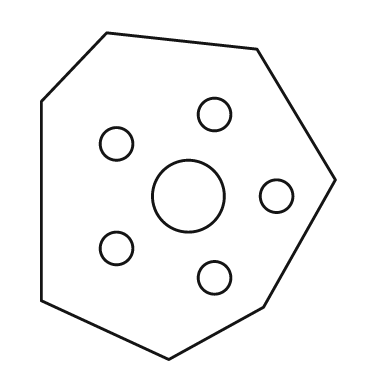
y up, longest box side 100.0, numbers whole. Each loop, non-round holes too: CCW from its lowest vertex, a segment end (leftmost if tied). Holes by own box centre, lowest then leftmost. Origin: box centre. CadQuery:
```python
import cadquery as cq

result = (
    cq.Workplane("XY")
    .moveTo(-6.0, -50.0)
    .lineTo(23.0, -34.0)
    .lineTo(45.0, 5.0)
    .lineTo(21.0, 45.0)
    .lineTo(-25.0, 50.0)
    .lineTo(-45.0, 29.0)
    .lineTo(-45.0, -32.0)
    .close()
    .moveTo(8.0, -25.0)
    .circle(5.0)
    .moveTo(-22.0, -16.0)
    .circle(5.0)
    .moveTo(0.0, 0.0)
    .circle(11.0)
    .moveTo(27.0, 0.0)
    .circle(5.0)
    .moveTo(-22.0, 16.0)
    .circle(5.0)
    .moveTo(8.0, 25.0)
    .circle(5.0)
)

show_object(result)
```